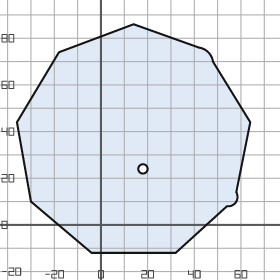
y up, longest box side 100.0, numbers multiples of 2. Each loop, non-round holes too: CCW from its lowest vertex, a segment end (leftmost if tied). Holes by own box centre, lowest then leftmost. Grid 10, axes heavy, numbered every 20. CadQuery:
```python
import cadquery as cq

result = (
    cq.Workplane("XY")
    .moveTo(-4.0, -12.0)
    .lineTo(32.0, -12.0)
    .lineTo(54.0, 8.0)
    .threePointArc((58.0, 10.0), (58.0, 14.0))
    .lineTo(64.0, 44.0)
    .lineTo(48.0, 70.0)
    .threePointArc((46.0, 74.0), (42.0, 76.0))
    .lineTo(14.0, 86.0)
    .lineTo(-18.0, 74.0)
    .lineTo(-36.0, 44.0)
    .lineTo(-30.0, 10.0)
    .close()
    .moveTo(18.0, 24.0)
    .circle(2.0)
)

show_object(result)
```